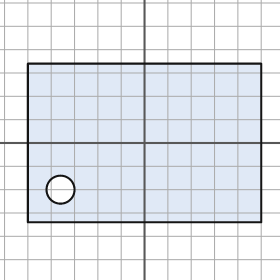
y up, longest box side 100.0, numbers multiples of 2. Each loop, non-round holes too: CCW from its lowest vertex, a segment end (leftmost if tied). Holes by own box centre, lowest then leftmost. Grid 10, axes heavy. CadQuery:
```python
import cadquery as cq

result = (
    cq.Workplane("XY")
    .moveTo(-50.0, -34.0)
    .lineTo(50.0, -34.0)
    .lineTo(50.0, 34.0)
    .lineTo(-50.0, 34.0)
    .close()
    .moveTo(-36.0, -20.0)
    .circle(6.0)
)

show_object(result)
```